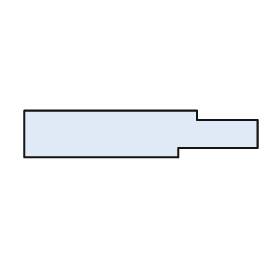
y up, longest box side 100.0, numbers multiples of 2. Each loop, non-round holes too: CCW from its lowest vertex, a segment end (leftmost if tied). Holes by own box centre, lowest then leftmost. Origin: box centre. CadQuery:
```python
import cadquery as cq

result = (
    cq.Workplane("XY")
    .moveTo(-50.0, -10.0)
    .lineTo(16.0, -10.0)
    .lineTo(16.0, -6.0)
    .lineTo(50.0, -6.0)
    .lineTo(50.0, 6.0)
    .lineTo(24.0, 6.0)
    .lineTo(24.0, 10.0)
    .lineTo(-50.0, 10.0)
    .close()
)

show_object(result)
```